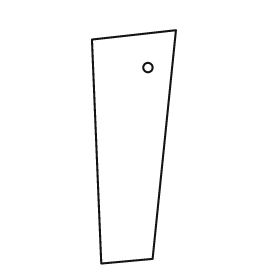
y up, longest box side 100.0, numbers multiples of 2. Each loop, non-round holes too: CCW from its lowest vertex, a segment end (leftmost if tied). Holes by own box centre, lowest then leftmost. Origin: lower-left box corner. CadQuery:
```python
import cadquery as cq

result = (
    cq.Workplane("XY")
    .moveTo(4.0, 0.0)
    .lineTo(26.0, 2.0)
    .lineTo(36.0, 100.0)
    .lineTo(0.0, 96.0)
    .close()
    .moveTo(24.0, 84.0)
    .circle(2.0)
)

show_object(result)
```